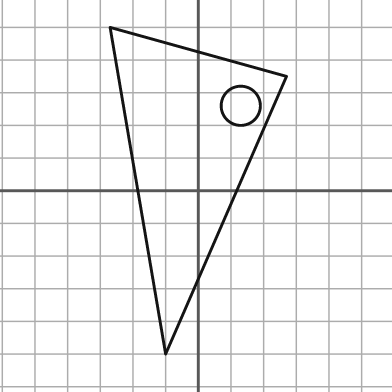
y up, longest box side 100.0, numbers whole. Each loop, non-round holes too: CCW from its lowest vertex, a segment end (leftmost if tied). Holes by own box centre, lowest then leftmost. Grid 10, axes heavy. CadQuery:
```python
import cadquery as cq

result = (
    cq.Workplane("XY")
    .moveTo(-10.0, -50.0)
    .lineTo(27.0, 35.0)
    .lineTo(-27.0, 50.0)
    .close()
    .moveTo(13.0, 26.0)
    .circle(6.0)
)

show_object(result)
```